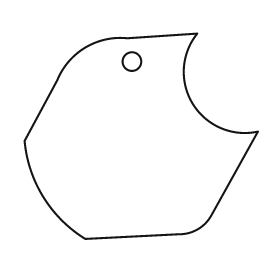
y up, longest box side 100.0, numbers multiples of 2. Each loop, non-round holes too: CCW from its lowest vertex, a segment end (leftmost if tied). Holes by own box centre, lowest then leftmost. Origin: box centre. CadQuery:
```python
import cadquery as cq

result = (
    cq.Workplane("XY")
    .moveTo(-24.0, -44.0)
    .lineTo(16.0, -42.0)
    .threePointArc((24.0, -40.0), (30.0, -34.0))
    .lineTo(50.0, 2.0)
    .threePointArc((22.0, 14.0), (24.0, 44.0))
    .lineTo(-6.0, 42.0)
    .threePointArc((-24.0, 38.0), (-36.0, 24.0))
    .lineTo(-50.0, -2.0)
    .threePointArc((-42.0, -26.0), (-24.0, -44.0))
    .close()
    .moveTo(-4.0, 32.0)
    .circle(4.0)
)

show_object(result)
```